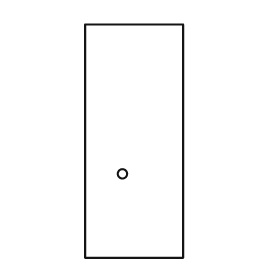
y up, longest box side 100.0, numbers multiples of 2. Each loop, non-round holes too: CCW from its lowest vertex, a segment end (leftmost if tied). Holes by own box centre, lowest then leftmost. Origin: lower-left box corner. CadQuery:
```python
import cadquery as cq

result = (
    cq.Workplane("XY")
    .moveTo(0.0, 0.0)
    .lineTo(42.0, 0.0)
    .lineTo(42.0, 100.0)
    .lineTo(0.0, 100.0)
    .close()
    .moveTo(16.0, 36.0)
    .circle(2.0)
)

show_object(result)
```